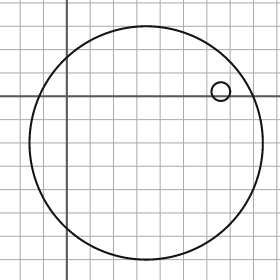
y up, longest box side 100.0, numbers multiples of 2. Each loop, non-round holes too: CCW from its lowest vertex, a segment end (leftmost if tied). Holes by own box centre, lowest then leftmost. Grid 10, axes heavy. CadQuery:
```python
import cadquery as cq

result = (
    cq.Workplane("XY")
    .moveTo(34.0, -20.0)
    .circle(50.0)
    .moveTo(66.0, 2.0)
    .circle(4.0)
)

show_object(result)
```